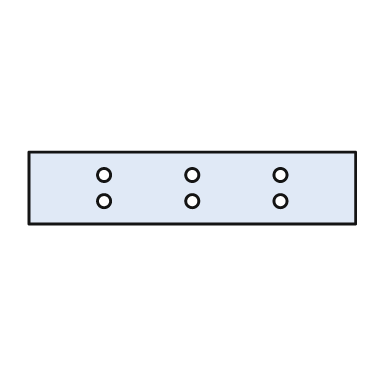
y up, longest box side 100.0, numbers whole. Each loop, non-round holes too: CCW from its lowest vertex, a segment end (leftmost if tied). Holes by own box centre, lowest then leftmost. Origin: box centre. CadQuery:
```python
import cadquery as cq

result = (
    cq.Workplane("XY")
    .moveTo(-50.0, -11.0)
    .lineTo(50.0, -11.0)
    .lineTo(50.0, 11.0)
    .lineTo(-50.0, 11.0)
    .close()
    .moveTo(-27.0, -4.0)
    .circle(2.0)
    .moveTo(0.0, -4.0)
    .circle(2.0)
    .moveTo(27.0, -4.0)
    .circle(2.0)
    .moveTo(-27.0, 4.0)
    .circle(2.0)
    .moveTo(0.0, 4.0)
    .circle(2.0)
    .moveTo(27.0, 4.0)
    .circle(2.0)
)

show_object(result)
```